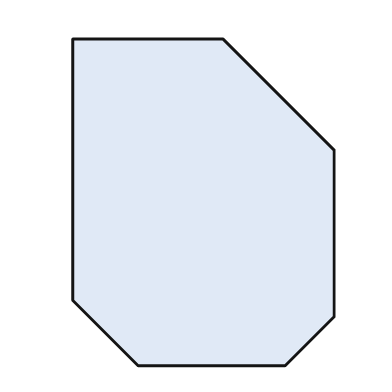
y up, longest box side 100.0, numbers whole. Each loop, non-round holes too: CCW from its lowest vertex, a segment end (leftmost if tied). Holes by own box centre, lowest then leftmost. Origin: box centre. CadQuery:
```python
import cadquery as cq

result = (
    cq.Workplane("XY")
    .moveTo(-20.0, -50.0)
    .lineTo(25.0, -50.0)
    .lineTo(40.0, -35.0)
    .lineTo(40.0, 16.0)
    .lineTo(6.0, 50.0)
    .lineTo(-40.0, 50.0)
    .lineTo(-40.0, -30.0)
    .close()
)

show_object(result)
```